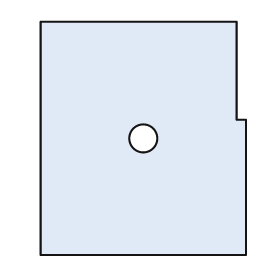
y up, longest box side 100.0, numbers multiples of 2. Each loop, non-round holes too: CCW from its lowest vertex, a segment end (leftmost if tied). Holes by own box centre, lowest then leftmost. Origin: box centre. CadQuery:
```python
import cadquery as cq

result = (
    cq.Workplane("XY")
    .moveTo(-44.0, -50.0)
    .lineTo(44.0, -50.0)
    .lineTo(44.0, 8.0)
    .lineTo(40.0, 8.0)
    .lineTo(40.0, 50.0)
    .lineTo(-44.0, 50.0)
    .close()
    .moveTo(0.0, 0.0)
    .circle(6.0)
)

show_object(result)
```